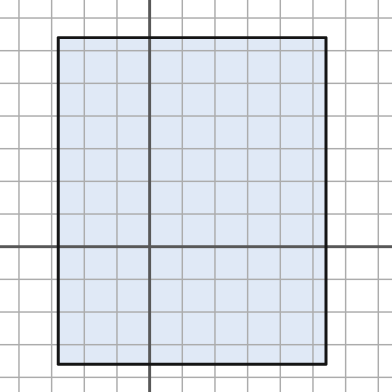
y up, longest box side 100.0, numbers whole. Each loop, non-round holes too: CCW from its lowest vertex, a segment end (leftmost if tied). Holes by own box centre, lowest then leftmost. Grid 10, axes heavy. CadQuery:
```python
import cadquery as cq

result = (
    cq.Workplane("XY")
    .moveTo(-28.0, -36.0)
    .lineTo(54.0, -36.0)
    .lineTo(54.0, 64.0)
    .lineTo(-28.0, 64.0)
    .close()
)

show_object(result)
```